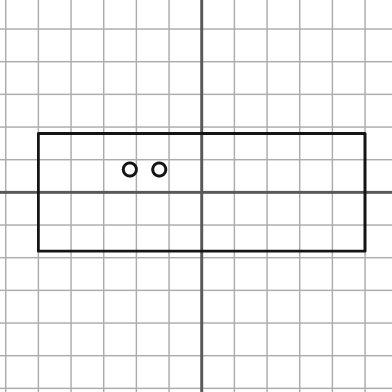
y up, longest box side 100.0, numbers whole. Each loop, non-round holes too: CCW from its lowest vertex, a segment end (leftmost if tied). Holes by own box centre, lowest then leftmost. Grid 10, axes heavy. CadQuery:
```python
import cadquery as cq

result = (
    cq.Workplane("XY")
    .moveTo(-50.0, -18.0)
    .lineTo(50.0, -18.0)
    .lineTo(50.0, 18.0)
    .lineTo(-50.0, 18.0)
    .close()
    .moveTo(-22.0, 7.0)
    .circle(2.0)
    .moveTo(-13.0, 7.0)
    .circle(2.0)
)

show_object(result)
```